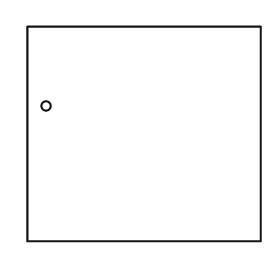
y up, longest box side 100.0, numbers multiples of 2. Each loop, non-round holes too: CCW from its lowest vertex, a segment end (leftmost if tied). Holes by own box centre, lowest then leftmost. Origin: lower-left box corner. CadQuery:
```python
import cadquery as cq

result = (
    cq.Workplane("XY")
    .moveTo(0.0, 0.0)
    .lineTo(100.0, 0.0)
    .lineTo(100.0, 92.0)
    .lineTo(0.0, 92.0)
    .close()
    .moveTo(8.0, 58.0)
    .circle(2.0)
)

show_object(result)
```